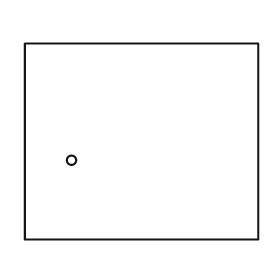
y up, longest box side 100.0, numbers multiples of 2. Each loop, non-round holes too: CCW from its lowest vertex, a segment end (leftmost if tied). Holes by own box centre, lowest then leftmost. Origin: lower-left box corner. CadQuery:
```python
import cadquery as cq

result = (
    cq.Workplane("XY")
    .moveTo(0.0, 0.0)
    .lineTo(100.0, 0.0)
    .lineTo(100.0, 84.0)
    .lineTo(0.0, 84.0)
    .close()
    .moveTo(20.0, 34.0)
    .circle(2.0)
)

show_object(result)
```